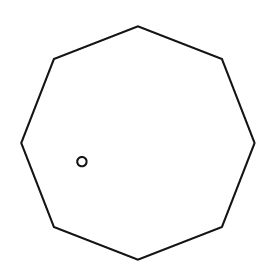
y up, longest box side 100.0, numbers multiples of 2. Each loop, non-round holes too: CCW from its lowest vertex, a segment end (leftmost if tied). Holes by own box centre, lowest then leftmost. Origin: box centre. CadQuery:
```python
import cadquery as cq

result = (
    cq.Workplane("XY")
    .moveTo(0.0, -50.0)
    .lineTo(36.0, -36.0)
    .lineTo(50.0, 0.0)
    .lineTo(36.0, 36.0)
    .lineTo(0.0, 50.0)
    .lineTo(-36.0, 36.0)
    .lineTo(-50.0, 0.0)
    .lineTo(-36.0, -36.0)
    .close()
    .moveTo(-24.0, -8.0)
    .circle(2.0)
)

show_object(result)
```